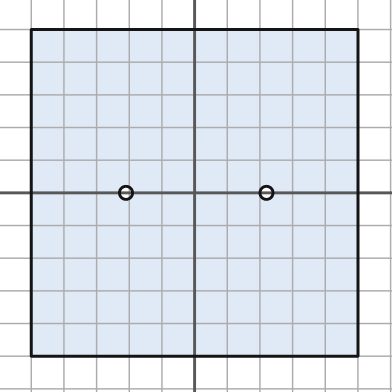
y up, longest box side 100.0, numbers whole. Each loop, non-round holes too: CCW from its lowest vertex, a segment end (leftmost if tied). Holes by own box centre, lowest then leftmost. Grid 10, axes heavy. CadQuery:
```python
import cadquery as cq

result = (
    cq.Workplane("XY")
    .moveTo(-50.0, -50.0)
    .lineTo(50.0, -50.0)
    .lineTo(50.0, 50.0)
    .lineTo(-50.0, 50.0)
    .close()
    .moveTo(-21.0, 0.0)
    .circle(2.0)
    .moveTo(22.0, 0.0)
    .circle(2.0)
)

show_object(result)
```